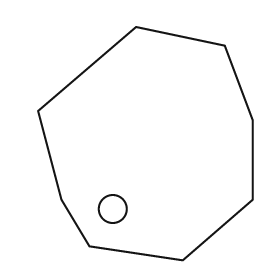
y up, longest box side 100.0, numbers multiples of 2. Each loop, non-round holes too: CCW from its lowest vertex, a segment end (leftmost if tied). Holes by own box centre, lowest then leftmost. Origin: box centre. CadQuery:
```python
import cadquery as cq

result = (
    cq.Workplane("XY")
    .moveTo(16.0, -50.0)
    .lineTo(46.0, -24.0)
    .lineTo(46.0, 10.0)
    .lineTo(34.0, 42.0)
    .lineTo(-4.0, 50.0)
    .lineTo(-46.0, 14.0)
    .lineTo(-36.0, -24.0)
    .lineTo(-24.0, -44.0)
    .close()
    .moveTo(-14.0, -28.0)
    .circle(6.0)
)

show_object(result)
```